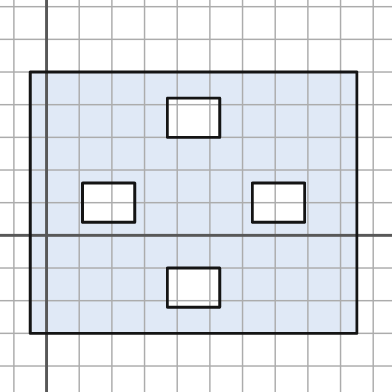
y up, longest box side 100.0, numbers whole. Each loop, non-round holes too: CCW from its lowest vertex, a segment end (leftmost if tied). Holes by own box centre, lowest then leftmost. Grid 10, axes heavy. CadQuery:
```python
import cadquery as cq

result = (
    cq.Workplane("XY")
    .moveTo(-5.0, -30.0)
    .lineTo(95.0, -30.0)
    .lineTo(95.0, 50.0)
    .lineTo(-5.0, 50.0)
    .close()
    .moveTo(37.0, -22.0)
    .lineTo(53.0, -22.0)
    .lineTo(53.0, -10.0)
    .lineTo(37.0, -10.0)
    .close()
    .moveTo(11.0, 4.0)
    .lineTo(27.0, 4.0)
    .lineTo(27.0, 16.0)
    .lineTo(11.0, 16.0)
    .close()
    .moveTo(63.0, 4.0)
    .lineTo(79.0, 4.0)
    .lineTo(79.0, 16.0)
    .lineTo(63.0, 16.0)
    .close()
    .moveTo(37.0, 30.0)
    .lineTo(53.0, 30.0)
    .lineTo(53.0, 42.0)
    .lineTo(37.0, 42.0)
    .close()
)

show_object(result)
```